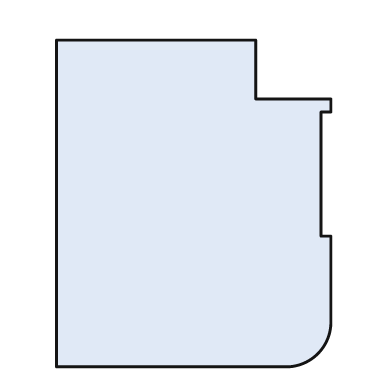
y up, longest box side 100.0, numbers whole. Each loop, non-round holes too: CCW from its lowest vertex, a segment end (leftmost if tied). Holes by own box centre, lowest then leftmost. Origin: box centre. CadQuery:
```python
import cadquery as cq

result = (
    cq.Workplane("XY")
    .moveTo(-42.0, -50.0)
    .lineTo(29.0, -50.0)
    .threePointArc((38.0, -46.0), (42.0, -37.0))
    .lineTo(42.0, -10.0)
    .lineTo(39.0, -10.0)
    .lineTo(39.0, 28.0)
    .lineTo(42.0, 28.0)
    .lineTo(42.0, 32.0)
    .lineTo(19.0, 32.0)
    .lineTo(19.0, 50.0)
    .lineTo(-42.0, 50.0)
    .close()
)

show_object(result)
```